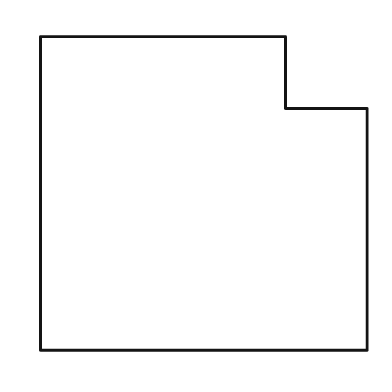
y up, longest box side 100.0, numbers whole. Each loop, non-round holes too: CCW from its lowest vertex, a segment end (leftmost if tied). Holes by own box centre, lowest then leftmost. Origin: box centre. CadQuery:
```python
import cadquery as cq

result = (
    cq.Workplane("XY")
    .moveTo(-50.0, -48.0)
    .lineTo(50.0, -48.0)
    .lineTo(50.0, 26.0)
    .lineTo(25.0, 26.0)
    .lineTo(25.0, 48.0)
    .lineTo(-50.0, 48.0)
    .close()
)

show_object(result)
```